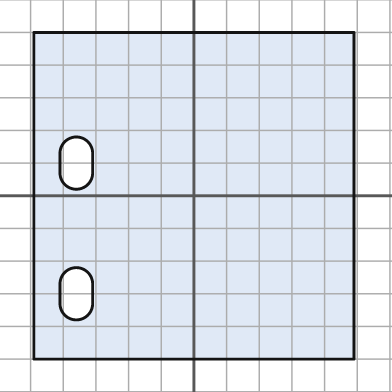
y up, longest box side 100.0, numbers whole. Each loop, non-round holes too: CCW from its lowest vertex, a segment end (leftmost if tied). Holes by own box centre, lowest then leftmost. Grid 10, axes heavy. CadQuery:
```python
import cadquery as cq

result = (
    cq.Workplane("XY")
    .moveTo(-49.0, -50.0)
    .lineTo(49.0, -50.0)
    .lineTo(49.0, 50.0)
    .lineTo(-49.0, 50.0)
    .close()
    .moveTo(-41.0, -33.0)
    .threePointArc((-36.0, -38.0), (-31.0, -33.0))
    .lineTo(-31.0, -27.0)
    .threePointArc((-36.0, -22.0), (-41.0, -27.0))
    .close()
    .moveTo(-41.0, 7.0)
    .threePointArc((-36.0, 2.0), (-31.0, 7.0))
    .lineTo(-31.0, 13.0)
    .threePointArc((-36.0, 18.0), (-41.0, 13.0))
    .close()
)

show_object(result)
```